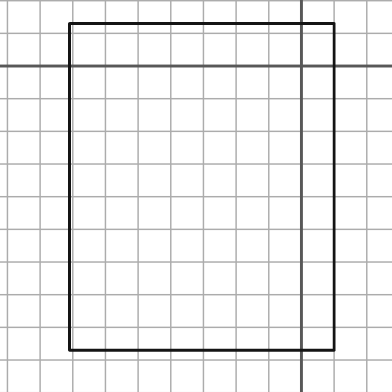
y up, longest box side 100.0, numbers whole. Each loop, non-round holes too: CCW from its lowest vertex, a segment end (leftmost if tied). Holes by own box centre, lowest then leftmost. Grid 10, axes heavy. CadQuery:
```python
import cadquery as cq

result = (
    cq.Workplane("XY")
    .moveTo(-71.0, -87.0)
    .lineTo(10.0, -87.0)
    .lineTo(10.0, 13.0)
    .lineTo(-71.0, 13.0)
    .close()
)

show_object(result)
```